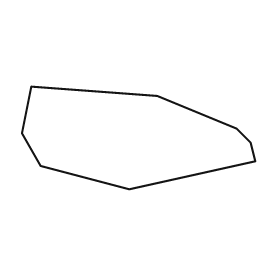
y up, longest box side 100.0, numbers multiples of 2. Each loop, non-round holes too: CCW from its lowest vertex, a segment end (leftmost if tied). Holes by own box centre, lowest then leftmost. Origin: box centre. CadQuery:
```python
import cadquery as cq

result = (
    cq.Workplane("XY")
    .moveTo(-4.0, -22.0)
    .lineTo(50.0, -10.0)
    .lineTo(48.0, -2.0)
    .lineTo(42.0, 4.0)
    .lineTo(8.0, 18.0)
    .lineTo(-46.0, 22.0)
    .lineTo(-50.0, 2.0)
    .lineTo(-42.0, -12.0)
    .close()
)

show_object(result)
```